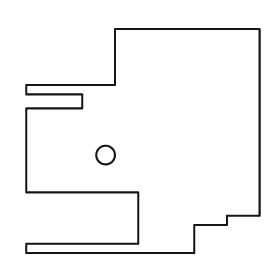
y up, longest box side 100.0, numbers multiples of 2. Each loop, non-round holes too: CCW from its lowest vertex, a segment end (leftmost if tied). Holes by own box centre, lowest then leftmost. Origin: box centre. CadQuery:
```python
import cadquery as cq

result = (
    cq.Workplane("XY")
    .moveTo(-50.0, -48.0)
    .lineTo(22.0, -48.0)
    .lineTo(22.0, -36.0)
    .lineTo(36.0, -36.0)
    .lineTo(36.0, -32.0)
    .lineTo(50.0, -32.0)
    .lineTo(50.0, 48.0)
    .lineTo(-12.0, 48.0)
    .lineTo(-12.0, 24.0)
    .lineTo(-50.0, 24.0)
    .lineTo(-50.0, 20.0)
    .lineTo(-26.0, 20.0)
    .lineTo(-26.0, 14.0)
    .lineTo(-50.0, 14.0)
    .lineTo(-50.0, -22.0)
    .lineTo(-2.0, -22.0)
    .lineTo(-2.0, -44.0)
    .lineTo(-50.0, -44.0)
    .close()
    .moveTo(-16.0, -6.0)
    .circle(4.0)
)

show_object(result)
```